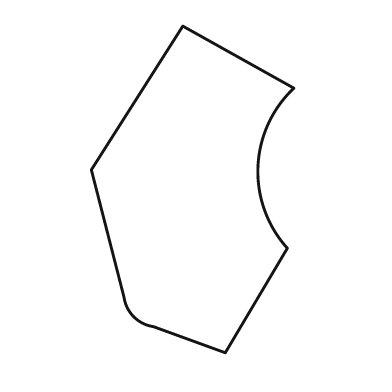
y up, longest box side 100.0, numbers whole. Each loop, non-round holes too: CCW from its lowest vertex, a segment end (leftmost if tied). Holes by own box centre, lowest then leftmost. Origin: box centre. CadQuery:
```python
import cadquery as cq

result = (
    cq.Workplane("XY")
    .moveTo(10.0, -50.0)
    .lineTo(29.0, -18.0)
    .threePointArc((20.0, 7.0), (31.0, 31.0))
    .lineTo(-3.0, 50.0)
    .lineTo(-31.0, 6.0)
    .lineTo(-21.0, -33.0)
    .threePointArc((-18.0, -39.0), (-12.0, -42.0))
    .close()
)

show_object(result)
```